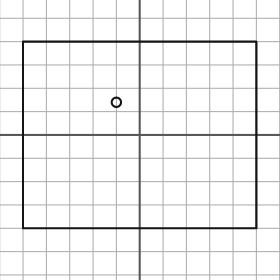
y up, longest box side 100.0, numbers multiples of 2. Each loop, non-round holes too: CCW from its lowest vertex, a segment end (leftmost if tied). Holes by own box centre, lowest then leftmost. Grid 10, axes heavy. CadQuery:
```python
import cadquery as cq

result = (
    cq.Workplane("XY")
    .moveTo(-50.0, -40.0)
    .lineTo(50.0, -40.0)
    .lineTo(50.0, 40.0)
    .lineTo(-50.0, 40.0)
    .close()
    .moveTo(-10.0, 14.0)
    .circle(2.0)
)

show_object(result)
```